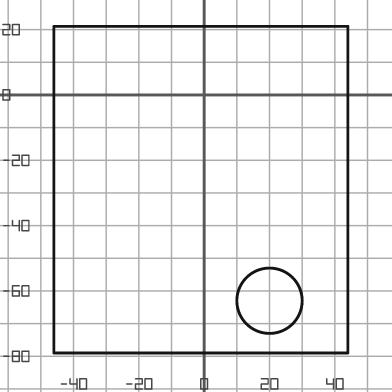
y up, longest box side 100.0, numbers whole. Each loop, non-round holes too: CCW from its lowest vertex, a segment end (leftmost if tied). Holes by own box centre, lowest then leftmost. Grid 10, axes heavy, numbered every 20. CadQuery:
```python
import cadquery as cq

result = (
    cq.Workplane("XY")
    .moveTo(-46.0, -79.0)
    .lineTo(44.0, -79.0)
    .lineTo(44.0, 21.0)
    .lineTo(-46.0, 21.0)
    .close()
    .moveTo(20.0, -63.0)
    .circle(10.0)
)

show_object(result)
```